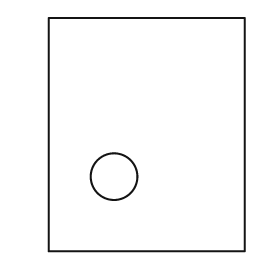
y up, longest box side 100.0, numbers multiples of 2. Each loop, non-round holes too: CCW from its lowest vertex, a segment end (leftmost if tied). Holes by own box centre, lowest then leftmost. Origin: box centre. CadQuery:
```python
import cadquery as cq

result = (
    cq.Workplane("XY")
    .moveTo(-42.0, -50.0)
    .lineTo(42.0, -50.0)
    .lineTo(42.0, 50.0)
    .lineTo(-42.0, 50.0)
    .close()
    .moveTo(-14.0, -18.0)
    .circle(10.0)
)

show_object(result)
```